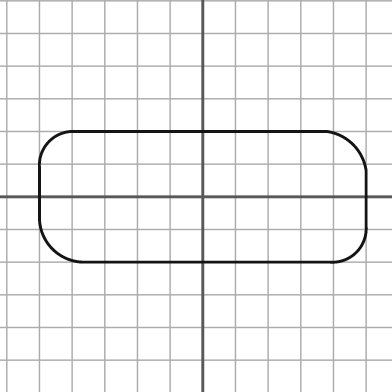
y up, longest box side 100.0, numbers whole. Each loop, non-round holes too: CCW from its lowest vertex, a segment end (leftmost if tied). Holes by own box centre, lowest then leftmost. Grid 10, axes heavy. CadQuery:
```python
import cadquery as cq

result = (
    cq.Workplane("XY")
    .moveTo(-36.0, -20.0)
    .lineTo(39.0, -20.0)
    .threePointArc((47.0, -17.0), (50.0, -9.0))
    .lineTo(50.0, 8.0)
    .threePointArc((46.0, 16.0), (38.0, 20.0))
    .lineTo(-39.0, 20.0)
    .threePointArc((-47.0, 17.0), (-50.0, 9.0))
    .lineTo(-50.0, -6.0)
    .threePointArc((-46.0, -16.0), (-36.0, -20.0))
    .close()
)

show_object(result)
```